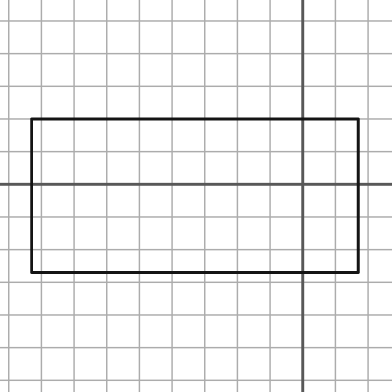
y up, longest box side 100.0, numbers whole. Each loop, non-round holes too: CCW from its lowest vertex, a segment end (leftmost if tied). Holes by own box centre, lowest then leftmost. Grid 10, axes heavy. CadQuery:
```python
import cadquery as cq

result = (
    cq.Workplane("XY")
    .moveTo(-83.0, -27.0)
    .lineTo(17.0, -27.0)
    .lineTo(17.0, 20.0)
    .lineTo(-83.0, 20.0)
    .close()
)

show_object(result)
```